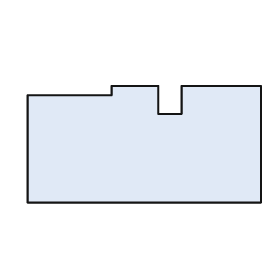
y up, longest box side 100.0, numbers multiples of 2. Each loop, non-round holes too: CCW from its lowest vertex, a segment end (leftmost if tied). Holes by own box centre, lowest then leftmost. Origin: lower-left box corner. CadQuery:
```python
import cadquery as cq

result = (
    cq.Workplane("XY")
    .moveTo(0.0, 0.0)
    .lineTo(100.0, 0.0)
    .lineTo(100.0, 50.0)
    .lineTo(66.0, 50.0)
    .lineTo(66.0, 38.0)
    .lineTo(56.0, 38.0)
    .lineTo(56.0, 50.0)
    .lineTo(36.0, 50.0)
    .lineTo(36.0, 46.0)
    .lineTo(0.0, 46.0)
    .close()
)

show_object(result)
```